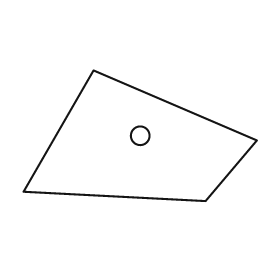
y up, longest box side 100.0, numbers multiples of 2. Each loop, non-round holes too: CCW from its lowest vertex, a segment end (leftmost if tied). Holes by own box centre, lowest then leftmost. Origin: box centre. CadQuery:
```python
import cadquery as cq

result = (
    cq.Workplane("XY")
    .moveTo(28.0, -28.0)
    .lineTo(50.0, -2.0)
    .lineTo(-20.0, 28.0)
    .lineTo(-50.0, -24.0)
    .close()
    .moveTo(0.0, 0.0)
    .circle(4.0)
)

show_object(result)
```